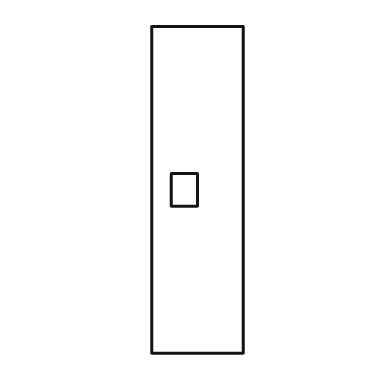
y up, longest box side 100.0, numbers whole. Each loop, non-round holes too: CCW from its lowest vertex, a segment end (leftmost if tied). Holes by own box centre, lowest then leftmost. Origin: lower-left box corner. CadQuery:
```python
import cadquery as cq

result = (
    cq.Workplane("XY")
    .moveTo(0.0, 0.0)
    .lineTo(28.0, 0.0)
    .lineTo(28.0, 100.0)
    .lineTo(0.0, 100.0)
    .close()
    .moveTo(6.0, 45.0)
    .lineTo(14.0, 45.0)
    .lineTo(14.0, 55.0)
    .lineTo(6.0, 55.0)
    .close()
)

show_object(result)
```